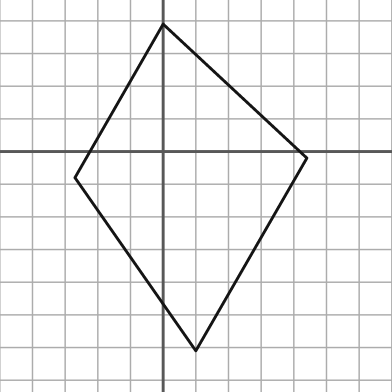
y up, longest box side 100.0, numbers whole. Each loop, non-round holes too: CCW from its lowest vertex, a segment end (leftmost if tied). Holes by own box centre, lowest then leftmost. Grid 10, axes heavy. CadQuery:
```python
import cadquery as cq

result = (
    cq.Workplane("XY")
    .moveTo(10.0, -61.0)
    .lineTo(44.0, -2.0)
    .lineTo(0.0, 39.0)
    .lineTo(-27.0, -8.0)
    .close()
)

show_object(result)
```